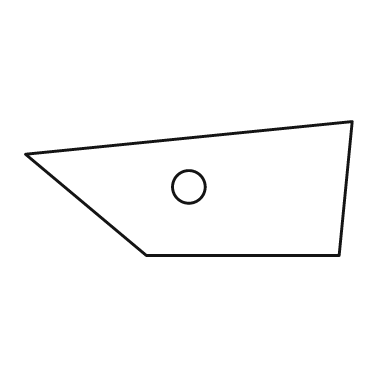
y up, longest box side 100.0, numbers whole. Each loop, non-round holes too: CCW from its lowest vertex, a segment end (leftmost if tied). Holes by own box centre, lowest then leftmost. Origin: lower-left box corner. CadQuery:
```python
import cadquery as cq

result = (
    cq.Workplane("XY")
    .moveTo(37.0, 0.0)
    .lineTo(96.0, 0.0)
    .lineTo(100.0, 41.0)
    .lineTo(0.0, 31.0)
    .close()
    .moveTo(50.0, 21.0)
    .circle(5.0)
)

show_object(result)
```